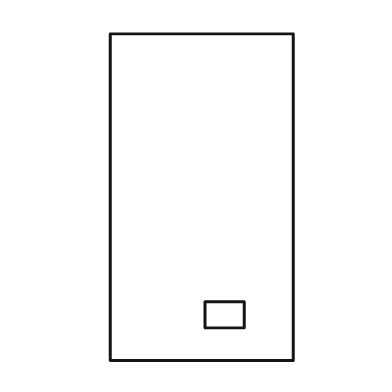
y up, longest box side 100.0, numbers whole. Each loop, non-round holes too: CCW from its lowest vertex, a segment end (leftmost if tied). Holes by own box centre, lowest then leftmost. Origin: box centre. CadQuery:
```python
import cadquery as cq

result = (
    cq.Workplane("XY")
    .moveTo(-28.0, -50.0)
    .lineTo(28.0, -50.0)
    .lineTo(28.0, 50.0)
    .lineTo(-28.0, 50.0)
    .close()
    .moveTo(1.0, -40.0)
    .lineTo(13.0, -40.0)
    .lineTo(13.0, -32.0)
    .lineTo(1.0, -32.0)
    .close()
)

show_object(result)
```